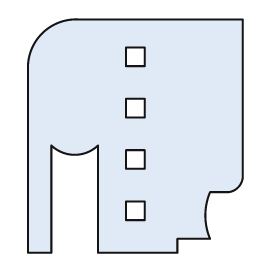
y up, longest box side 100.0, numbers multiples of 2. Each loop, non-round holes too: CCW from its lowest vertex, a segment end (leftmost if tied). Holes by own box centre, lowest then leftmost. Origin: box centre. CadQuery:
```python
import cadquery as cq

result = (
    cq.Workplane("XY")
    .moveTo(-46.0, -50.0)
    .lineTo(-36.0, -50.0)
    .lineTo(-36.0, -4.0)
    .threePointArc((-26.0, -8.0), (-16.0, -4.0))
    .lineTo(-16.0, -50.0)
    .lineTo(18.0, -50.0)
    .lineTo(18.0, -44.0)
    .lineTo(32.0, -44.0)
    .threePointArc((30.0, -34.0), (32.0, -24.0))
    .lineTo(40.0, -24.0)
    .threePointArc((44.0, -22.0), (46.0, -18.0))
    .lineTo(46.0, 50.0)
    .lineTo(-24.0, 50.0)
    .threePointArc((-40.0, 44.0), (-46.0, 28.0))
    .close()
    .moveTo(-4.0, -36.0)
    .lineTo(4.0, -36.0)
    .lineTo(4.0, -28.0)
    .lineTo(-4.0, -28.0)
    .close()
    .moveTo(-4.0, -14.0)
    .lineTo(4.0, -14.0)
    .lineTo(4.0, -6.0)
    .lineTo(-4.0, -6.0)
    .close()
    .moveTo(-4.0, 8.0)
    .lineTo(4.0, 8.0)
    .lineTo(4.0, 16.0)
    .lineTo(-4.0, 16.0)
    .close()
    .moveTo(-4.0, 30.0)
    .lineTo(4.0, 30.0)
    .lineTo(4.0, 38.0)
    .lineTo(-4.0, 38.0)
    .close()
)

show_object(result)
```